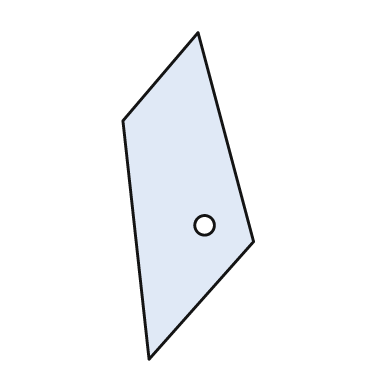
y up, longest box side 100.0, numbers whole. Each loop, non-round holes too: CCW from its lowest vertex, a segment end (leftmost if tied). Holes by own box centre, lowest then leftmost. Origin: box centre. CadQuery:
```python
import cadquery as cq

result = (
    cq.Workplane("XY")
    .moveTo(-12.0, -50.0)
    .lineTo(20.0, -14.0)
    .lineTo(3.0, 50.0)
    .lineTo(-20.0, 23.0)
    .close()
    .moveTo(5.0, -9.0)
    .circle(3.0)
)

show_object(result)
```